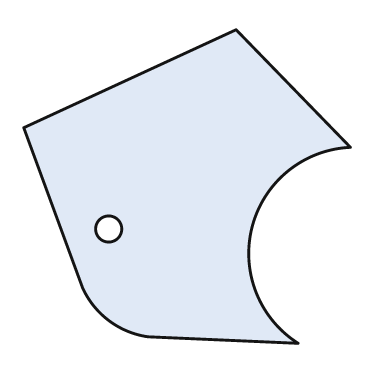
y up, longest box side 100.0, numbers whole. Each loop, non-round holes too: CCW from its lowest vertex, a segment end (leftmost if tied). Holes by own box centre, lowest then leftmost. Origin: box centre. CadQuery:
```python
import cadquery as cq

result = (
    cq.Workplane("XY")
    .moveTo(34.0, -48.0)
    .threePointArc((20.0, -12.0), (50.0, 12.0))
    .lineTo(15.0, 48.0)
    .lineTo(-50.0, 18.0)
    .lineTo(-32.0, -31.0)
    .threePointArc((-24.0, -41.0), (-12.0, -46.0))
    .close()
    .moveTo(-24.0, -13.0)
    .circle(4.0)
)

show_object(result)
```